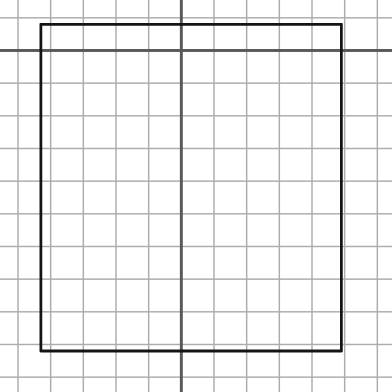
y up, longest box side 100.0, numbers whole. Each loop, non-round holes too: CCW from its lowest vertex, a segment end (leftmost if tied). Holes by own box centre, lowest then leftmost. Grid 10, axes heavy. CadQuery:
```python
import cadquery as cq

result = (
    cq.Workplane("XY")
    .moveTo(-43.0, -92.0)
    .lineTo(49.0, -92.0)
    .lineTo(49.0, 8.0)
    .lineTo(-43.0, 8.0)
    .close()
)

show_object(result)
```